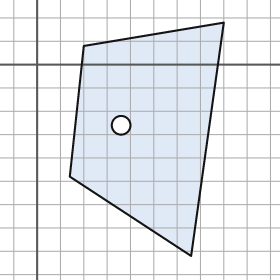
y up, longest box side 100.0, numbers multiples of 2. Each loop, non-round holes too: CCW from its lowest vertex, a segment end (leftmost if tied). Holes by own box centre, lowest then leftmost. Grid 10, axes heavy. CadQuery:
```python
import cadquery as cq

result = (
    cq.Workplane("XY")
    .moveTo(66.0, -82.0)
    .lineTo(80.0, 18.0)
    .lineTo(20.0, 8.0)
    .lineTo(14.0, -48.0)
    .close()
    .moveTo(36.0, -26.0)
    .circle(4.0)
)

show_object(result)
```